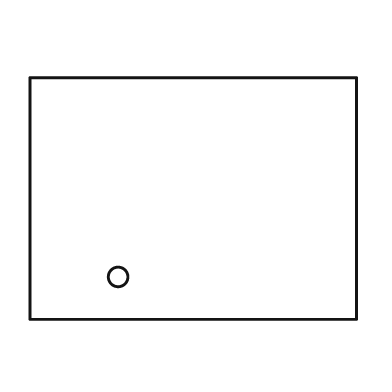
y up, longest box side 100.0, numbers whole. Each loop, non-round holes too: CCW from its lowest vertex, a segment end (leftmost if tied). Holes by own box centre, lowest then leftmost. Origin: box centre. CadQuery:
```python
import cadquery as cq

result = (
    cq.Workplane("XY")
    .moveTo(-50.0, -37.0)
    .lineTo(50.0, -37.0)
    .lineTo(50.0, 37.0)
    .lineTo(-50.0, 37.0)
    .close()
    .moveTo(-23.0, -24.0)
    .circle(3.0)
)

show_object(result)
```